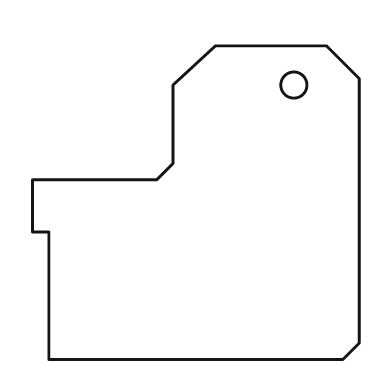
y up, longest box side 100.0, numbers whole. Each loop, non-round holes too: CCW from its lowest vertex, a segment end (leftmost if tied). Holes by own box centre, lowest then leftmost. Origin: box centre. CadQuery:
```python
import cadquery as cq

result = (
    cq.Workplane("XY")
    .moveTo(-45.0, -48.0)
    .lineTo(45.0, -48.0)
    .lineTo(50.0, -43.0)
    .lineTo(50.0, 38.0)
    .lineTo(40.0, 48.0)
    .lineTo(6.0, 48.0)
    .lineTo(-7.0, 36.0)
    .lineTo(-7.0, 12.0)
    .lineTo(-12.0, 7.0)
    .lineTo(-50.0, 7.0)
    .lineTo(-50.0, -9.0)
    .lineTo(-45.0, -9.0)
    .close()
    .moveTo(30.0, 36.0)
    .circle(4.0)
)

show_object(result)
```